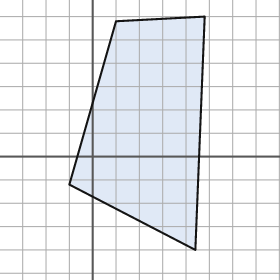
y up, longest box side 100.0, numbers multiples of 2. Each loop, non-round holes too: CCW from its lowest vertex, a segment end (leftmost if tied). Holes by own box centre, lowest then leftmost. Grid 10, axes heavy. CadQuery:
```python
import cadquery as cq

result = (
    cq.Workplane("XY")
    .moveTo(44.0, -40.0)
    .lineTo(48.0, 60.0)
    .lineTo(10.0, 58.0)
    .lineTo(-10.0, -12.0)
    .close()
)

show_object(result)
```